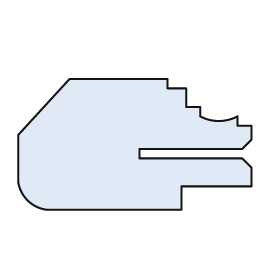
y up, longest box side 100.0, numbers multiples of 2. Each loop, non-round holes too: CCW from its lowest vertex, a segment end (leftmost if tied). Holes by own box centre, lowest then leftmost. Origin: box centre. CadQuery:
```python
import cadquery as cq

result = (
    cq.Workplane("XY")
    .moveTo(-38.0, -28.0)
    .lineTo(20.0, -28.0)
    .lineTo(20.0, -18.0)
    .lineTo(50.0, -18.0)
    .lineTo(50.0, -10.0)
    .lineTo(46.0, -6.0)
    .lineTo(2.0, -6.0)
    .lineTo(2.0, -2.0)
    .lineTo(46.0, -2.0)
    .lineTo(50.0, 2.0)
    .lineTo(50.0, 8.0)
    .lineTo(44.0, 8.0)
    .lineTo(44.0, 12.0)
    .threePointArc((36.0, 10.0), (28.0, 12.0))
    .lineTo(28.0, 16.0)
    .lineTo(22.0, 16.0)
    .lineTo(22.0, 24.0)
    .lineTo(14.0, 24.0)
    .lineTo(14.0, 28.0)
    .lineTo(-28.0, 28.0)
    .lineTo(-50.0, 4.0)
    .lineTo(-50.0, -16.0)
    .threePointArc((-46.0, -24.0), (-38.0, -28.0))
    .close()
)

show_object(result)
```